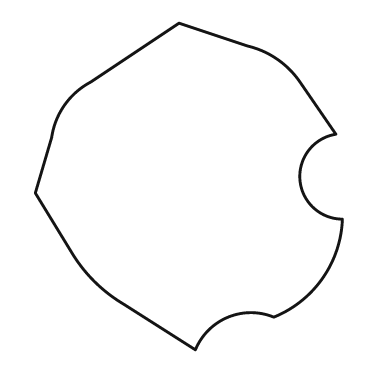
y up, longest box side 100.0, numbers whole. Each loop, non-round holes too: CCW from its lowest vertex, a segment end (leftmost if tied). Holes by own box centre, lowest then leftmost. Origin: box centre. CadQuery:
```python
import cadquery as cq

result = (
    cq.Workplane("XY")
    .moveTo(2.0, -50.0)
    .threePointArc((12.0, -40.0), (26.0, -40.0))
    .threePointArc((41.0, -28.0), (47.0, -10.0))
    .threePointArc((34.0, 2.0), (45.0, 16.0))
    .lineTo(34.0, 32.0)
    .threePointArc((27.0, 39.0), (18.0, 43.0))
    .lineTo(-3.0, 50.0)
    .lineTo(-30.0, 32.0)
    .threePointArc((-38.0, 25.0), (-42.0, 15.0))
    .lineTo(-47.0, -2.0)
    .lineTo(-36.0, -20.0)
    .threePointArc((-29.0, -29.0), (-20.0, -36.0))
    .close()
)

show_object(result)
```